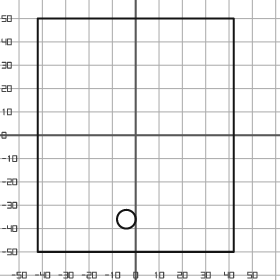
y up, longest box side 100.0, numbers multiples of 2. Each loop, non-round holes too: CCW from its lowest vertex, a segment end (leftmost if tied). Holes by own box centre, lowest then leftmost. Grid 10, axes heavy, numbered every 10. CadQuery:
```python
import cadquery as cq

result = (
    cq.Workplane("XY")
    .moveTo(-42.0, -50.0)
    .lineTo(42.0, -50.0)
    .lineTo(42.0, 50.0)
    .lineTo(-42.0, 50.0)
    .close()
    .moveTo(-4.0, -36.0)
    .circle(4.0)
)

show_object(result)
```